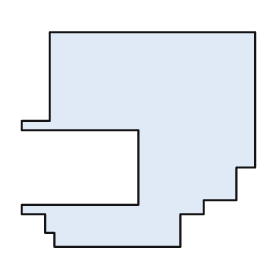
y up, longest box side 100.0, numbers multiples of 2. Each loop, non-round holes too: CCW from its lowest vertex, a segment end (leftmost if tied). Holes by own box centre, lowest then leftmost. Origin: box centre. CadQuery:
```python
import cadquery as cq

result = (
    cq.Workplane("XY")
    .moveTo(-36.0, -46.0)
    .lineTo(18.0, -46.0)
    .lineTo(18.0, -32.0)
    .lineTo(28.0, -32.0)
    .lineTo(28.0, -26.0)
    .lineTo(42.0, -26.0)
    .lineTo(42.0, -12.0)
    .lineTo(50.0, -12.0)
    .lineTo(50.0, 46.0)
    .lineTo(-38.0, 46.0)
    .lineTo(-38.0, 8.0)
    .lineTo(-50.0, 8.0)
    .lineTo(-50.0, 4.0)
    .lineTo(0.0, 4.0)
    .lineTo(0.0, -28.0)
    .lineTo(-50.0, -28.0)
    .lineTo(-50.0, -32.0)
    .lineTo(-40.0, -32.0)
    .lineTo(-40.0, -40.0)
    .lineTo(-36.0, -40.0)
    .close()
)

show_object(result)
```